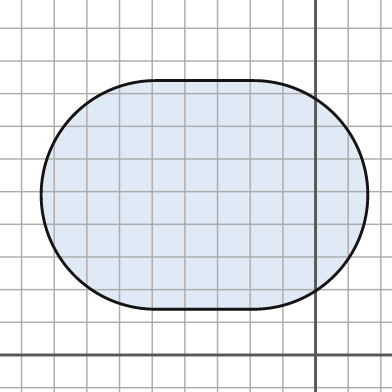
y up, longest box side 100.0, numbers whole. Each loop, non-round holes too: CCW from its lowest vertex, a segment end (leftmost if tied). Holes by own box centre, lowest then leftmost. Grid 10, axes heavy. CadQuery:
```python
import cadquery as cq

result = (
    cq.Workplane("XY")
    .moveTo(-49.0, 14.0)
    .lineTo(-19.0, 14.0)
    .threePointArc((16.0, 49.0), (-19.0, 84.0))
    .lineTo(-49.0, 84.0)
    .threePointArc((-84.0, 49.0), (-49.0, 14.0))
    .close()
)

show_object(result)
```